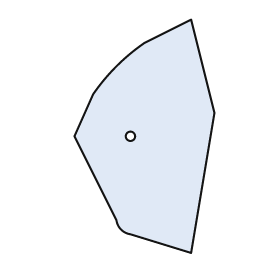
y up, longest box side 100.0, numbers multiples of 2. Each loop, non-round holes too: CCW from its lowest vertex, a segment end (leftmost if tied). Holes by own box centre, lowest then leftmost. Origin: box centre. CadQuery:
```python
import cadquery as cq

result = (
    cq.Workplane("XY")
    .moveTo(20.0, -50.0)
    .lineTo(30.0, 10.0)
    .lineTo(20.0, 50.0)
    .lineTo(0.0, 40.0)
    .threePointArc((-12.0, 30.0), (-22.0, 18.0))
    .lineTo(-30.0, 0.0)
    .lineTo(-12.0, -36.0)
    .threePointArc((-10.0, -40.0), (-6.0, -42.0))
    .close()
    .moveTo(-6.0, 0.0)
    .circle(2.0)
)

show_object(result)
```